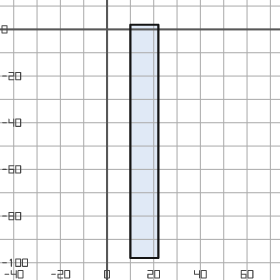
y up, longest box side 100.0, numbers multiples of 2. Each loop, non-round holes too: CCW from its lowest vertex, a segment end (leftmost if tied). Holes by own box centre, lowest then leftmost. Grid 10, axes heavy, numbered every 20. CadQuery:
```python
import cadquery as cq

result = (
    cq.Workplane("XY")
    .moveTo(10.0, -98.0)
    .lineTo(22.0, -98.0)
    .lineTo(22.0, 2.0)
    .lineTo(10.0, 2.0)
    .close()
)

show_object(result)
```